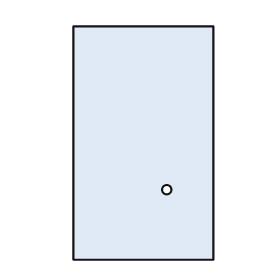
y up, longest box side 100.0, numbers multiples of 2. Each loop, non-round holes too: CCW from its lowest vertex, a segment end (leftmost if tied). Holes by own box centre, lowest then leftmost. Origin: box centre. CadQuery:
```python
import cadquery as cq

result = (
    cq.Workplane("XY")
    .moveTo(-30.0, -50.0)
    .lineTo(30.0, -50.0)
    .lineTo(30.0, 50.0)
    .lineTo(-30.0, 50.0)
    .close()
    .moveTo(10.0, -20.0)
    .circle(2.0)
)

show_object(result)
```